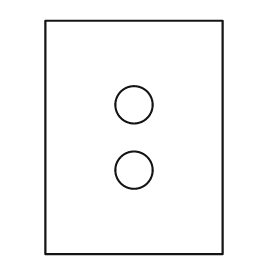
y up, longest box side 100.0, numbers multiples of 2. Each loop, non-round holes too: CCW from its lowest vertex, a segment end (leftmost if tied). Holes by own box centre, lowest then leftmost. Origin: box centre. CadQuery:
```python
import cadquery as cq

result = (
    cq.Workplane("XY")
    .moveTo(-38.0, -50.0)
    .lineTo(38.0, -50.0)
    .lineTo(38.0, 50.0)
    .lineTo(-38.0, 50.0)
    .close()
    .moveTo(0.0, -14.0)
    .circle(8.0)
    .moveTo(0.0, 14.0)
    .circle(8.0)
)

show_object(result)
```